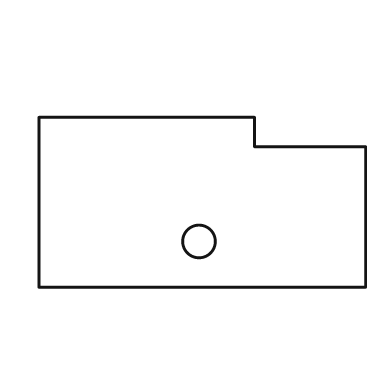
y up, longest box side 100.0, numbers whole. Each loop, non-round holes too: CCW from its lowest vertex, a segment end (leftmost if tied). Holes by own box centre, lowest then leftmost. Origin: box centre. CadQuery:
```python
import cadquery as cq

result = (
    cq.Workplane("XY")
    .moveTo(-50.0, -26.0)
    .lineTo(50.0, -26.0)
    .lineTo(50.0, 17.0)
    .lineTo(16.0, 17.0)
    .lineTo(16.0, 26.0)
    .lineTo(-50.0, 26.0)
    .close()
    .moveTo(-1.0, -12.0)
    .circle(5.0)
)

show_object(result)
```